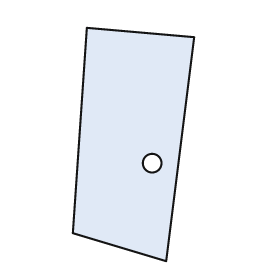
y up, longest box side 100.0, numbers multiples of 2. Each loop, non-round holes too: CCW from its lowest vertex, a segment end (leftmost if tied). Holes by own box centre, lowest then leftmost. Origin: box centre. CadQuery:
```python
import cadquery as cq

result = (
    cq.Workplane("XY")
    .moveTo(14.0, -50.0)
    .lineTo(26.0, 46.0)
    .lineTo(-20.0, 50.0)
    .lineTo(-26.0, -38.0)
    .close()
    .moveTo(8.0, -8.0)
    .circle(4.0)
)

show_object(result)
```